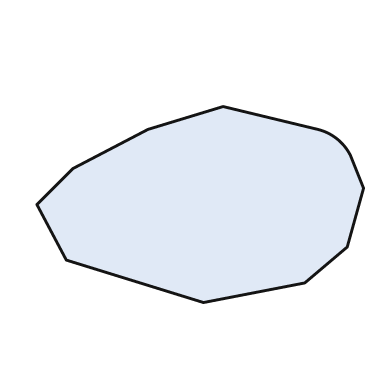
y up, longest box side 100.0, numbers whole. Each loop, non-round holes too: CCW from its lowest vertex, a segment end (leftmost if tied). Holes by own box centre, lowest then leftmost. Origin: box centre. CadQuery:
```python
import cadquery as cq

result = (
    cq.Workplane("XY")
    .moveTo(1.0, -30.0)
    .lineTo(32.0, -24.0)
    .lineTo(45.0, -13.0)
    .lineTo(50.0, 5.0)
    .lineTo(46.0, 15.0)
    .threePointArc((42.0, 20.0), (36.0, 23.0))
    .lineTo(7.0, 30.0)
    .lineTo(-16.0, 23.0)
    .lineTo(-39.0, 11.0)
    .lineTo(-50.0, 0.0)
    .lineTo(-41.0, -17.0)
    .close()
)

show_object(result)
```